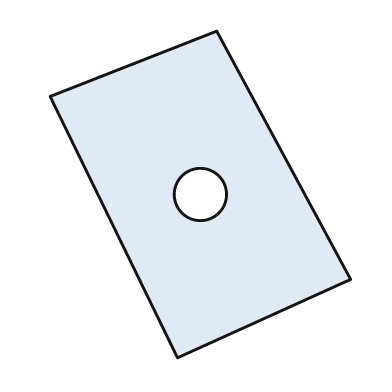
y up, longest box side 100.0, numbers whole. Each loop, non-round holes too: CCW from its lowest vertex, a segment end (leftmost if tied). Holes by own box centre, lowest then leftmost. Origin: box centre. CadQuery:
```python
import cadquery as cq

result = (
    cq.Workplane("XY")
    .moveTo(-7.0, -50.0)
    .lineTo(46.0, -26.0)
    .lineTo(5.0, 50.0)
    .lineTo(-46.0, 30.0)
    .close()
    .moveTo(0.0, 0.0)
    .circle(8.0)
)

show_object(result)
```